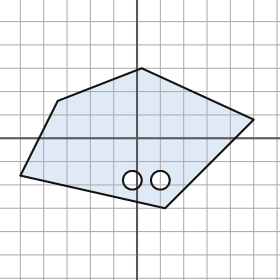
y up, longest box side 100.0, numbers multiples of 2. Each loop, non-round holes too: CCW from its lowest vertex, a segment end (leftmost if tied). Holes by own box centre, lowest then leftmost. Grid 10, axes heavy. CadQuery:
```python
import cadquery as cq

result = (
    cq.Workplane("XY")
    .moveTo(12.0, -30.0)
    .lineTo(50.0, 8.0)
    .lineTo(2.0, 30.0)
    .lineTo(-34.0, 16.0)
    .lineTo(-50.0, -16.0)
    .close()
    .moveTo(-2.0, -18.0)
    .circle(4.0)
    .moveTo(10.0, -18.0)
    .circle(4.0)
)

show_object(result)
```